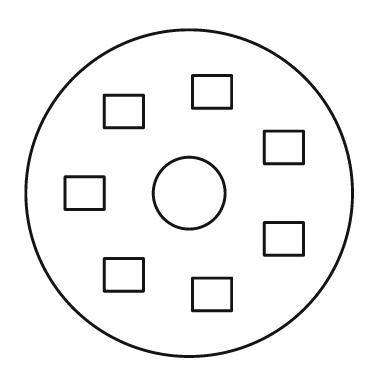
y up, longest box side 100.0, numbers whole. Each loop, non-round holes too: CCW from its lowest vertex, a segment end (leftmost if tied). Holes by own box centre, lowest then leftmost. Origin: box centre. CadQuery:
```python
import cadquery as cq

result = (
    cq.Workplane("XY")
    .moveTo(0.0, 0.0)
    .circle(50.0)
    .moveTo(1.0, -36.0)
    .lineTo(13.0, -36.0)
    .lineTo(13.0, -26.0)
    .lineTo(1.0, -26.0)
    .close()
    .moveTo(-26.0, -30.0)
    .lineTo(-14.0, -30.0)
    .lineTo(-14.0, -20.0)
    .lineTo(-26.0, -20.0)
    .close()
    .moveTo(23.0, -19.0)
    .lineTo(35.0, -19.0)
    .lineTo(35.0, -9.0)
    .lineTo(23.0, -9.0)
    .close()
    .moveTo(-38.0, -5.0)
    .lineTo(-26.0, -5.0)
    .lineTo(-26.0, 5.0)
    .lineTo(-38.0, 5.0)
    .close()
    .moveTo(0.0, 0.0)
    .circle(11.0)
    .moveTo(23.0, 9.0)
    .lineTo(35.0, 9.0)
    .lineTo(35.0, 19.0)
    .lineTo(23.0, 19.0)
    .close()
    .moveTo(-26.0, 20.0)
    .lineTo(-14.0, 20.0)
    .lineTo(-14.0, 30.0)
    .lineTo(-26.0, 30.0)
    .close()
    .moveTo(1.0, 26.0)
    .lineTo(13.0, 26.0)
    .lineTo(13.0, 36.0)
    .lineTo(1.0, 36.0)
    .close()
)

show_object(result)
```